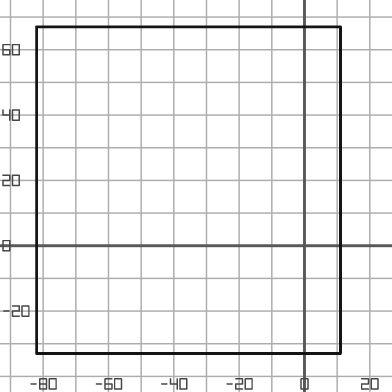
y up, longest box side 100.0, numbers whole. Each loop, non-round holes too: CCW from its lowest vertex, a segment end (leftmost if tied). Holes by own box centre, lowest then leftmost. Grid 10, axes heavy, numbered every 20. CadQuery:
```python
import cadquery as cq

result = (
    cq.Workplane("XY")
    .moveTo(-82.0, -33.0)
    .lineTo(11.0, -33.0)
    .lineTo(11.0, 67.0)
    .lineTo(-82.0, 67.0)
    .close()
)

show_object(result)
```